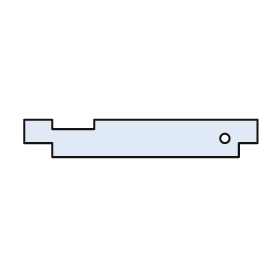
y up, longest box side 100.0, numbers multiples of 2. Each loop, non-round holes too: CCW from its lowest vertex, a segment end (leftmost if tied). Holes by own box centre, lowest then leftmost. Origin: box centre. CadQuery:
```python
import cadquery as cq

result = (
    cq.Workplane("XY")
    .moveTo(-38.0, -8.0)
    .lineTo(42.0, -8.0)
    .lineTo(42.0, -2.0)
    .lineTo(50.0, -2.0)
    .lineTo(50.0, 8.0)
    .lineTo(-20.0, 8.0)
    .lineTo(-20.0, 4.0)
    .lineTo(-38.0, 4.0)
    .lineTo(-38.0, 8.0)
    .lineTo(-50.0, 8.0)
    .lineTo(-50.0, -2.0)
    .lineTo(-38.0, -2.0)
    .close()
    .moveTo(36.0, 0.0)
    .circle(2.0)
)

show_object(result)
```